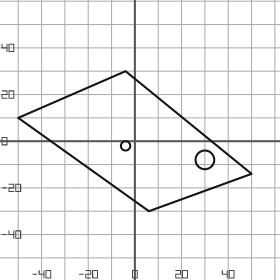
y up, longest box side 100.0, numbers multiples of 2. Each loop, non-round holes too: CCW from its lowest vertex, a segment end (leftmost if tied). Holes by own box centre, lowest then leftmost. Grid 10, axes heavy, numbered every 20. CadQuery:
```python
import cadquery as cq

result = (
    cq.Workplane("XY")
    .moveTo(6.0, -30.0)
    .lineTo(50.0, -14.0)
    .lineTo(-4.0, 30.0)
    .lineTo(-50.0, 10.0)
    .close()
    .moveTo(30.0, -8.0)
    .circle(4.0)
    .moveTo(-4.0, -2.0)
    .circle(2.0)
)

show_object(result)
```